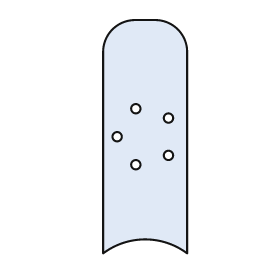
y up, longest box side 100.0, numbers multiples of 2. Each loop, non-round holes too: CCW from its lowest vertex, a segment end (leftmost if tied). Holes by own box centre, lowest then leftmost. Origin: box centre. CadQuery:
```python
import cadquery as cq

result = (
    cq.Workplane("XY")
    .moveTo(-18.0, -50.0)
    .threePointArc((0.0, -44.0), (18.0, -50.0))
    .lineTo(18.0, 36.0)
    .threePointArc((14.0, 46.0), (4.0, 50.0))
    .lineTo(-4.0, 50.0)
    .threePointArc((-14.0, 46.0), (-18.0, 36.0))
    .close()
    .moveTo(-4.0, -12.0)
    .circle(2.0)
    .moveTo(10.0, -8.0)
    .circle(2.0)
    .moveTo(-12.0, 0.0)
    .circle(2.0)
    .moveTo(10.0, 8.0)
    .circle(2.0)
    .moveTo(-4.0, 12.0)
    .circle(2.0)
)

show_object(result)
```